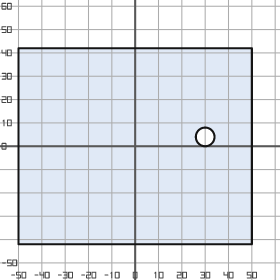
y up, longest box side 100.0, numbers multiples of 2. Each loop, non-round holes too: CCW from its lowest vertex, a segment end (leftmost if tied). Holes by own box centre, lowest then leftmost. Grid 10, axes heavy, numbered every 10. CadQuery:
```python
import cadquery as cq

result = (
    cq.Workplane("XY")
    .moveTo(-50.0, -42.0)
    .lineTo(50.0, -42.0)
    .lineTo(50.0, 42.0)
    .lineTo(-50.0, 42.0)
    .close()
    .moveTo(30.0, 4.0)
    .circle(4.0)
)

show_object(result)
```